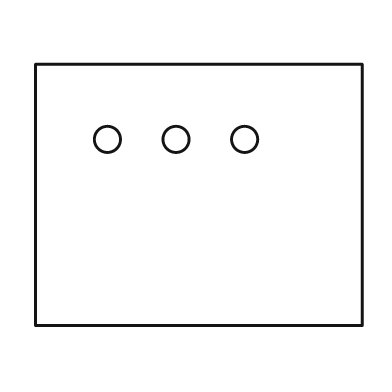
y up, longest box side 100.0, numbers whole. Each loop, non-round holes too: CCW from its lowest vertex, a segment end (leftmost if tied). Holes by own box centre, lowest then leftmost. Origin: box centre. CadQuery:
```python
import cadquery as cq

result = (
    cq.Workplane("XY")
    .moveTo(-50.0, -40.0)
    .lineTo(50.0, -40.0)
    .lineTo(50.0, 40.0)
    .lineTo(-50.0, 40.0)
    .close()
    .moveTo(-28.0, 17.0)
    .circle(4.0)
    .moveTo(-7.0, 17.0)
    .circle(4.0)
    .moveTo(14.0, 17.0)
    .circle(4.0)
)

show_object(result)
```